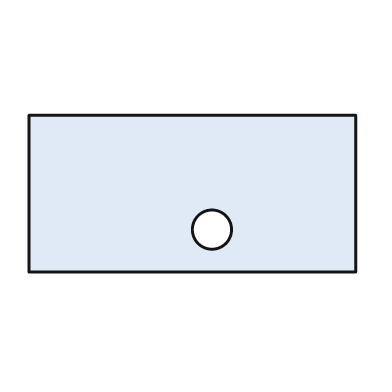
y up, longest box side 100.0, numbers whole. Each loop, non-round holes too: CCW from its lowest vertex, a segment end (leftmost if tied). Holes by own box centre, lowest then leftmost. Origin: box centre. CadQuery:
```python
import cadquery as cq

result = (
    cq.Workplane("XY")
    .moveTo(-50.0, -24.0)
    .lineTo(50.0, -24.0)
    .lineTo(50.0, 24.0)
    .lineTo(-50.0, 24.0)
    .close()
    .moveTo(6.0, -11.0)
    .circle(6.0)
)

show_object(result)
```